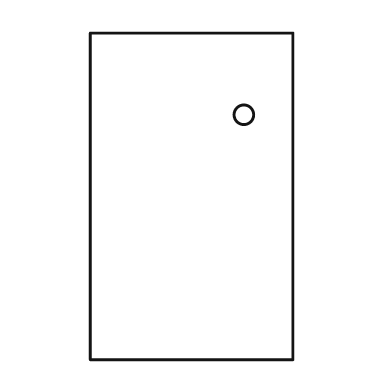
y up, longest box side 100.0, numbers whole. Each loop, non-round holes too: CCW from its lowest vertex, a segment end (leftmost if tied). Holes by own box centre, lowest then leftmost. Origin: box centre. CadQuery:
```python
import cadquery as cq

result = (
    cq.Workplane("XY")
    .moveTo(-31.0, -50.0)
    .lineTo(31.0, -50.0)
    .lineTo(31.0, 50.0)
    .lineTo(-31.0, 50.0)
    .close()
    .moveTo(16.0, 25.0)
    .circle(3.0)
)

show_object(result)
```